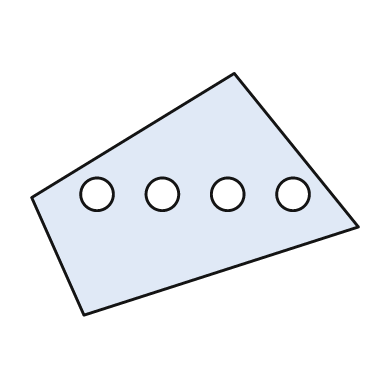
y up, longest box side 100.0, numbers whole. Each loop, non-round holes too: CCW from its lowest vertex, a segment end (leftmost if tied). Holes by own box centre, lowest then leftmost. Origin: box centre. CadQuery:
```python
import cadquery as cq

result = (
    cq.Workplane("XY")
    .moveTo(-34.0, -37.0)
    .lineTo(50.0, -10.0)
    .lineTo(12.0, 37.0)
    .lineTo(-50.0, -1.0)
    .close()
    .moveTo(-30.0, 0.0)
    .circle(5.0)
    .moveTo(-10.0, 0.0)
    .circle(5.0)
    .moveTo(10.0, 0.0)
    .circle(5.0)
    .moveTo(30.0, 0.0)
    .circle(5.0)
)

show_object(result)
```